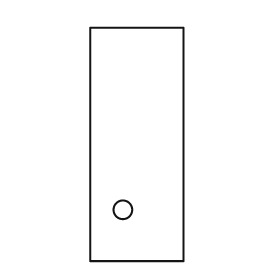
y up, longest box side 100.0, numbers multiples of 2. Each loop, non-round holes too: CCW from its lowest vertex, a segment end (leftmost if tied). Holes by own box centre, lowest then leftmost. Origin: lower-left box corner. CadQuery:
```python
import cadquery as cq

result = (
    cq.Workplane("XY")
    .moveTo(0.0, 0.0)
    .lineTo(40.0, 0.0)
    .lineTo(40.0, 100.0)
    .lineTo(0.0, 100.0)
    .close()
    .moveTo(14.0, 22.0)
    .circle(4.0)
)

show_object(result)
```